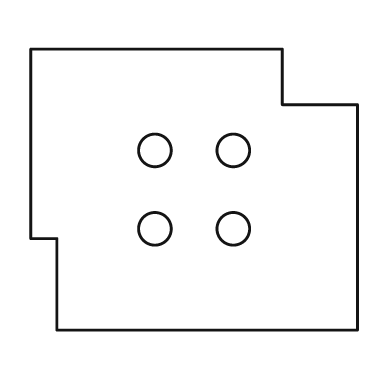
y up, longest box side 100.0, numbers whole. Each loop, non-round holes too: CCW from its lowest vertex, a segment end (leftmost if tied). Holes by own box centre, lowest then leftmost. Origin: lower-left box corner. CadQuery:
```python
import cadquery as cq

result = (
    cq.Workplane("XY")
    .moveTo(8.0, 0.0)
    .lineTo(100.0, 0.0)
    .lineTo(100.0, 69.0)
    .lineTo(77.0, 69.0)
    .lineTo(77.0, 86.0)
    .lineTo(0.0, 86.0)
    .lineTo(0.0, 28.0)
    .lineTo(8.0, 28.0)
    .close()
    .moveTo(38.0, 31.0)
    .circle(5.0)
    .moveTo(62.0, 31.0)
    .circle(5.0)
    .moveTo(38.0, 55.0)
    .circle(5.0)
    .moveTo(62.0, 55.0)
    .circle(5.0)
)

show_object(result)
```